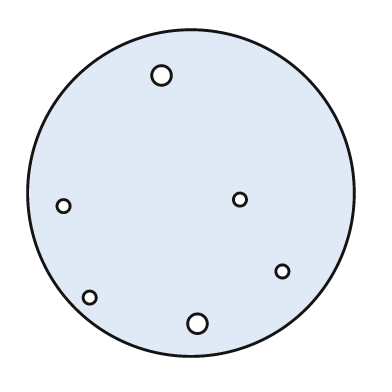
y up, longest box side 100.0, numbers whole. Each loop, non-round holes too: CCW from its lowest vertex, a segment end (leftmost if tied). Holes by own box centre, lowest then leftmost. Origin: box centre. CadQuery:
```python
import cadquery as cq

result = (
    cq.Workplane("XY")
    .moveTo(0.0, 0.0)
    .circle(50.0)
    .moveTo(2.0, -40.0)
    .circle(3.0)
    .moveTo(-31.0, -32.0)
    .circle(2.0)
    .moveTo(28.0, -24.0)
    .circle(2.0)
    .moveTo(-39.0, -4.0)
    .circle(2.0)
    .moveTo(15.0, -2.0)
    .circle(2.0)
    .moveTo(-9.0, 36.0)
    .circle(3.0)
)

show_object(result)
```